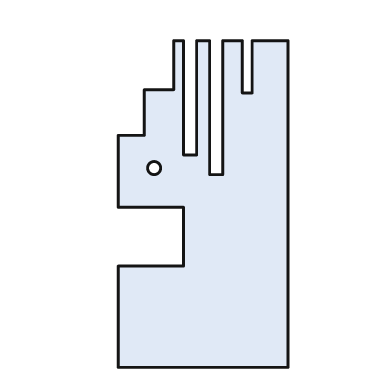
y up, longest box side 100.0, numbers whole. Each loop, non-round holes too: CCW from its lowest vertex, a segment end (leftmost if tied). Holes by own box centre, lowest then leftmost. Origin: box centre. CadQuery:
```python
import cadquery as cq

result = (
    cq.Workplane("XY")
    .moveTo(-26.0, -50.0)
    .lineTo(26.0, -50.0)
    .lineTo(26.0, 50.0)
    .lineTo(15.0, 50.0)
    .lineTo(15.0, 34.0)
    .lineTo(12.0, 34.0)
    .lineTo(12.0, 50.0)
    .lineTo(6.0, 50.0)
    .lineTo(6.0, 9.0)
    .lineTo(2.0, 9.0)
    .lineTo(2.0, 50.0)
    .lineTo(-2.0, 50.0)
    .lineTo(-2.0, 15.0)
    .lineTo(-6.0, 15.0)
    .lineTo(-6.0, 50.0)
    .lineTo(-9.0, 50.0)
    .lineTo(-9.0, 35.0)
    .lineTo(-18.0, 35.0)
    .lineTo(-18.0, 21.0)
    .lineTo(-26.0, 21.0)
    .lineTo(-26.0, -1.0)
    .lineTo(-6.0, -1.0)
    .lineTo(-6.0, -19.0)
    .lineTo(-26.0, -19.0)
    .close()
    .moveTo(-15.0, 11.0)
    .circle(2.0)
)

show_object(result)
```